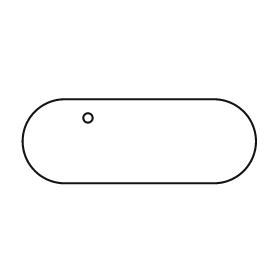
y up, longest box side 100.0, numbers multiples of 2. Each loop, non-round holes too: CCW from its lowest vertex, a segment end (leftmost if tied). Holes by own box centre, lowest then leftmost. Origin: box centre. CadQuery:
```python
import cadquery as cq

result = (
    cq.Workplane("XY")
    .moveTo(-32.0, -18.0)
    .lineTo(32.0, -18.0)
    .threePointArc((50.0, 0.0), (32.0, 18.0))
    .lineTo(-32.0, 18.0)
    .threePointArc((-50.0, 0.0), (-32.0, -18.0))
    .close()
    .moveTo(-22.0, 10.0)
    .circle(2.0)
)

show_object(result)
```